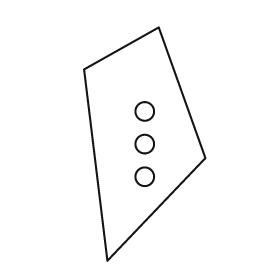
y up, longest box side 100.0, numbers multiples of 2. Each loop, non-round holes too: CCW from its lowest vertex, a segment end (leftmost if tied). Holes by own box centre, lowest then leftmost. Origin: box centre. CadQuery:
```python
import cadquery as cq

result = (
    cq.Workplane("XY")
    .moveTo(-16.0, -50.0)
    .lineTo(26.0, -6.0)
    .lineTo(6.0, 50.0)
    .lineTo(-26.0, 32.0)
    .close()
    .moveTo(0.0, -14.0)
    .circle(4.0)
    .moveTo(0.0, 0.0)
    .circle(4.0)
    .moveTo(0.0, 14.0)
    .circle(4.0)
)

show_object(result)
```